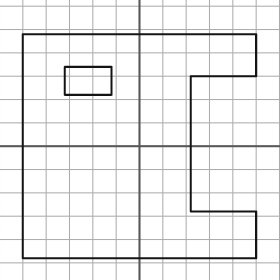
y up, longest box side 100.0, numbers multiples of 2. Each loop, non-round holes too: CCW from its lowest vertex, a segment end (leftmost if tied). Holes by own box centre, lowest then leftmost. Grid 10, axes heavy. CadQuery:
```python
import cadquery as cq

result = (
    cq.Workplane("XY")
    .moveTo(-50.0, -48.0)
    .lineTo(50.0, -48.0)
    .lineTo(50.0, -28.0)
    .lineTo(22.0, -28.0)
    .lineTo(22.0, 30.0)
    .lineTo(50.0, 30.0)
    .lineTo(50.0, 48.0)
    .lineTo(-50.0, 48.0)
    .close()
    .moveTo(-32.0, 22.0)
    .lineTo(-12.0, 22.0)
    .lineTo(-12.0, 34.0)
    .lineTo(-32.0, 34.0)
    .close()
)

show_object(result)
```